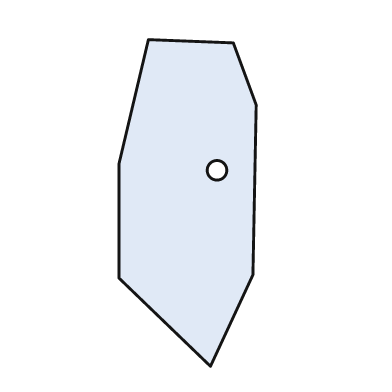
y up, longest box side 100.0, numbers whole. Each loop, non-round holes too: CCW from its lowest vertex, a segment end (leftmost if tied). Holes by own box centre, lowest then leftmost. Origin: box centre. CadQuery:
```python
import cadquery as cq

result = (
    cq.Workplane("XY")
    .moveTo(7.0, -50.0)
    .lineTo(20.0, -22.0)
    .lineTo(21.0, 30.0)
    .lineTo(14.0, 49.0)
    .lineTo(-12.0, 50.0)
    .lineTo(-21.0, 12.0)
    .lineTo(-21.0, -23.0)
    .close()
    .moveTo(9.0, 10.0)
    .circle(3.0)
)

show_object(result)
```